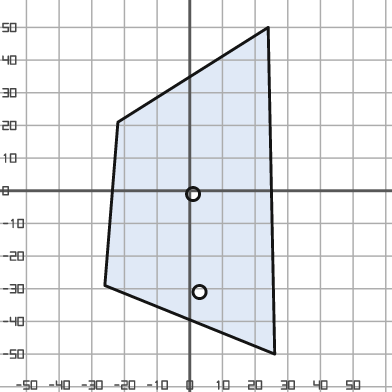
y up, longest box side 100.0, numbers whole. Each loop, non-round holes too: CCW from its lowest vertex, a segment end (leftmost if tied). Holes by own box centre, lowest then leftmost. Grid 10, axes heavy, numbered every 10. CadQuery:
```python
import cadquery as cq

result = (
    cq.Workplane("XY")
    .moveTo(26.0, -50.0)
    .lineTo(24.0, 50.0)
    .lineTo(-22.0, 21.0)
    .lineTo(-26.0, -29.0)
    .close()
    .moveTo(3.0, -31.0)
    .circle(2.0)
    .moveTo(1.0, -1.0)
    .circle(2.0)
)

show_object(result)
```